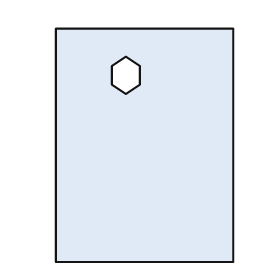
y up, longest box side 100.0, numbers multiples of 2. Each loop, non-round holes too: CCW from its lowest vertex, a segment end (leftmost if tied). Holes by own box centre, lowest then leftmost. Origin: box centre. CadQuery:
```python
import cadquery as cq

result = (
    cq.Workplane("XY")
    .moveTo(-38.0, -50.0)
    .lineTo(38.0, -50.0)
    .lineTo(38.0, 50.0)
    .lineTo(-38.0, 50.0)
    .close()
    .moveTo(-8.0, 22.0)
    .lineTo(-2.0, 26.0)
    .lineTo(-2.0, 34.0)
    .lineTo(-8.0, 38.0)
    .lineTo(-14.0, 34.0)
    .lineTo(-14.0, 26.0)
    .close()
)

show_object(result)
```